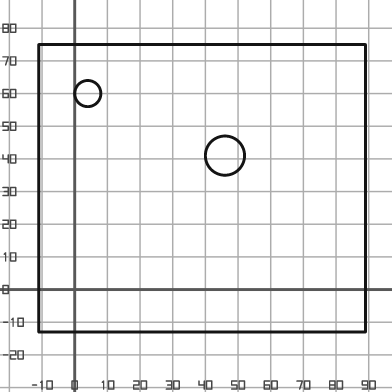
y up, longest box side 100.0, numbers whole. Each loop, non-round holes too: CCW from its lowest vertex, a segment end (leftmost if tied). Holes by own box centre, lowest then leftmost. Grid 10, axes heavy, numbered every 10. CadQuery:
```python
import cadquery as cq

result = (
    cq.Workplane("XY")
    .moveTo(-11.0, -13.0)
    .lineTo(89.0, -13.0)
    .lineTo(89.0, 75.0)
    .lineTo(-11.0, 75.0)
    .close()
    .moveTo(46.0, 41.0)
    .circle(6.0)
    .moveTo(4.0, 60.0)
    .circle(4.0)
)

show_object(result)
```